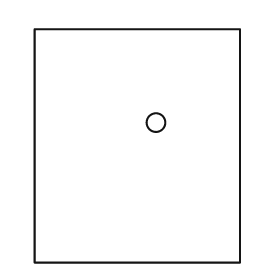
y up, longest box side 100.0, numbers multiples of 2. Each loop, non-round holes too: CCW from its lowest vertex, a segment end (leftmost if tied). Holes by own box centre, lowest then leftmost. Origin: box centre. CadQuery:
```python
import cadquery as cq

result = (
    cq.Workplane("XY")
    .moveTo(-44.0, -50.0)
    .lineTo(44.0, -50.0)
    .lineTo(44.0, 50.0)
    .lineTo(-44.0, 50.0)
    .close()
    .moveTo(8.0, 10.0)
    .circle(4.0)
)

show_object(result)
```